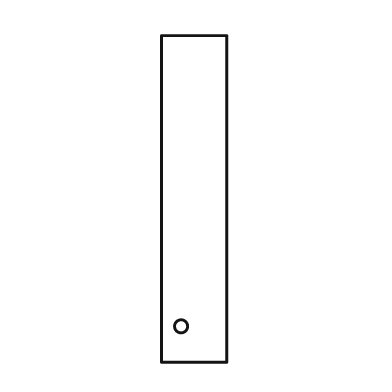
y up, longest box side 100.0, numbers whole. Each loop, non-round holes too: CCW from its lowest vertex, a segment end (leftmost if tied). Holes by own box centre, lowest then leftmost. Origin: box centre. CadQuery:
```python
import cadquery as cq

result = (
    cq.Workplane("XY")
    .moveTo(-10.0, -50.0)
    .lineTo(10.0, -50.0)
    .lineTo(10.0, 50.0)
    .lineTo(-10.0, 50.0)
    .close()
    .moveTo(-4.0, -39.0)
    .circle(2.0)
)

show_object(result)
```